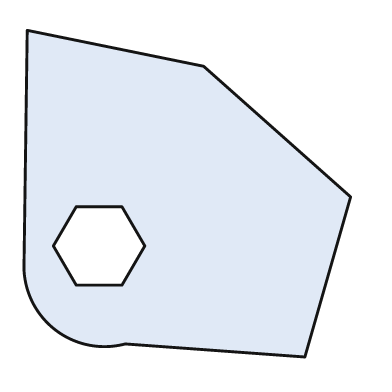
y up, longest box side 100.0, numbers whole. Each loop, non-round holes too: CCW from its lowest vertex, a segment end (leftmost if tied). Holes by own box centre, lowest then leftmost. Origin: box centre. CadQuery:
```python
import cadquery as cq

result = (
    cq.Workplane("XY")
    .moveTo(36.0, -50.0)
    .lineTo(50.0, -1.0)
    .lineTo(5.0, 39.0)
    .lineTo(-49.0, 50.0)
    .lineTo(-50.0, -23.0)
    .threePointArc((-40.0, -42.0), (-19.0, -46.0))
    .close()
    .moveTo(-34.0, -28.0)
    .lineTo(-20.0, -28.0)
    .lineTo(-13.0, -16.0)
    .lineTo(-20.0, -4.0)
    .lineTo(-34.0, -4.0)
    .lineTo(-41.0, -16.0)
    .close()
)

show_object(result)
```